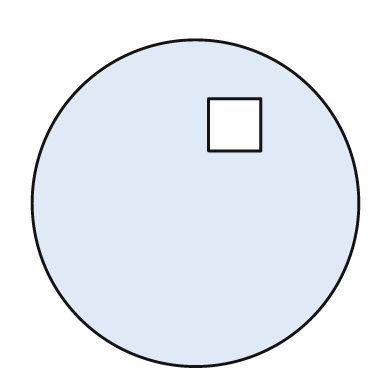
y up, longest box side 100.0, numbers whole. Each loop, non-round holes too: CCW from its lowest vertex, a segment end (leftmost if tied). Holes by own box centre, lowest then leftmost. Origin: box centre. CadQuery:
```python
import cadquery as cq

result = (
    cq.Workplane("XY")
    .moveTo(0.0, 0.0)
    .circle(50.0)
    .moveTo(4.0, 16.0)
    .lineTo(20.0, 16.0)
    .lineTo(20.0, 32.0)
    .lineTo(4.0, 32.0)
    .close()
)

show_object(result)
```